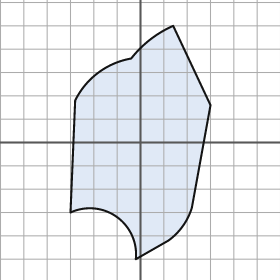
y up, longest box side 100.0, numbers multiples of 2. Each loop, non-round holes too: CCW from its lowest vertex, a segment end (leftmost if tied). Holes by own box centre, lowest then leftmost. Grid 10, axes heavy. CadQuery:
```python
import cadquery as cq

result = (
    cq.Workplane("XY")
    .moveTo(-2.0, -50.0)
    .lineTo(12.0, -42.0)
    .threePointArc((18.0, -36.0), (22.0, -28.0))
    .lineTo(30.0, 16.0)
    .lineTo(14.0, 50.0)
    .threePointArc((4.0, 44.0), (-4.0, 36.0))
    .threePointArc((-18.0, 30.0), (-28.0, 18.0))
    .lineTo(-30.0, -30.0)
    .threePointArc((-10.0, -32.0), (-2.0, -50.0))
    .close()
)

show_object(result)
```